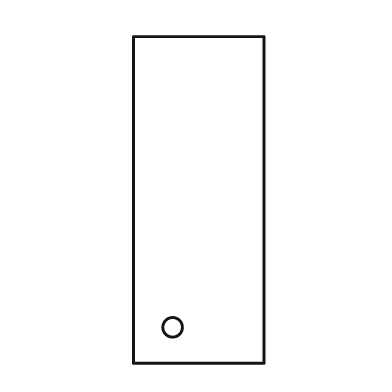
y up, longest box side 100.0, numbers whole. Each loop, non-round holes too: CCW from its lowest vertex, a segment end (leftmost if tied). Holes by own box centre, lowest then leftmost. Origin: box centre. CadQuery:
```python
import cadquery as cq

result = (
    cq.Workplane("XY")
    .moveTo(-20.0, -50.0)
    .lineTo(20.0, -50.0)
    .lineTo(20.0, 50.0)
    .lineTo(-20.0, 50.0)
    .close()
    .moveTo(-8.0, -39.0)
    .circle(3.0)
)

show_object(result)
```